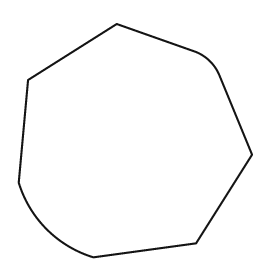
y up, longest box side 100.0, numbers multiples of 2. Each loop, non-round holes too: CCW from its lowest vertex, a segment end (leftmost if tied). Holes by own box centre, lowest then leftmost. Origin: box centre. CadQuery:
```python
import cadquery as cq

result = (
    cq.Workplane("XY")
    .moveTo(-18.0, -50.0)
    .lineTo(26.0, -44.0)
    .lineTo(50.0, -6.0)
    .lineTo(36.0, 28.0)
    .threePointArc((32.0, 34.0), (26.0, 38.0))
    .lineTo(-8.0, 50.0)
    .lineTo(-46.0, 26.0)
    .lineTo(-50.0, -18.0)
    .threePointArc((-38.0, -38.0), (-18.0, -50.0))
    .close()
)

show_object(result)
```